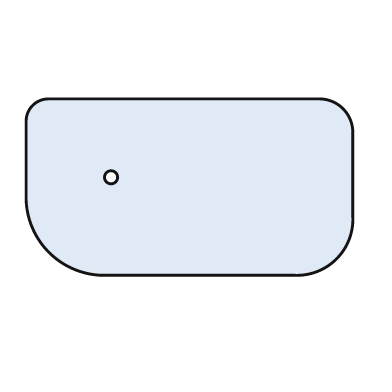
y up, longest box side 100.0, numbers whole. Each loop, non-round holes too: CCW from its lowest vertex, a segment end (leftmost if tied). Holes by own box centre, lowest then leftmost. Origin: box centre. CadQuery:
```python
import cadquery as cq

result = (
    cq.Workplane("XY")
    .moveTo(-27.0, -27.0)
    .lineTo(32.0, -27.0)
    .threePointArc((45.0, -22.0), (50.0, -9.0))
    .lineTo(50.0, 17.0)
    .threePointArc((47.0, 24.0), (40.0, 27.0))
    .lineTo(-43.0, 27.0)
    .threePointArc((-48.0, 25.0), (-50.0, 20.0))
    .lineTo(-50.0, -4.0)
    .threePointArc((-43.0, -20.0), (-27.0, -27.0))
    .close()
    .moveTo(-24.0, 3.0)
    .circle(2.0)
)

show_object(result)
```